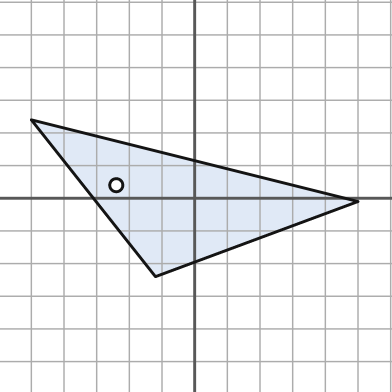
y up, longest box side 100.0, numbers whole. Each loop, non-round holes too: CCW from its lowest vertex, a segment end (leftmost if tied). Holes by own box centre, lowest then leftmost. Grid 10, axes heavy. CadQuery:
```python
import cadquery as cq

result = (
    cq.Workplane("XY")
    .moveTo(-12.0, -24.0)
    .lineTo(50.0, -1.0)
    .lineTo(-50.0, 24.0)
    .close()
    .moveTo(-24.0, 4.0)
    .circle(2.0)
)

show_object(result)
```